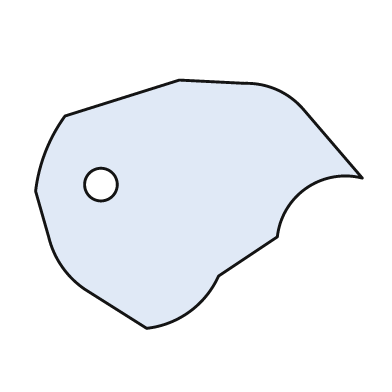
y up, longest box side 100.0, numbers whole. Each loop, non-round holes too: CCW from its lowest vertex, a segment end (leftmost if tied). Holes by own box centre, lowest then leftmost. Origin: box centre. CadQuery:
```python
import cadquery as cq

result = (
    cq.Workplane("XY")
    .moveTo(-16.0, -38.0)
    .threePointArc((-3.0, -33.0), (6.0, -22.0))
    .lineTo(24.0, -10.0)
    .threePointArc((33.0, 5.0), (50.0, 8.0))
    .lineTo(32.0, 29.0)
    .threePointArc((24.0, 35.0), (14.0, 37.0))
    .lineTo(-6.0, 38.0)
    .lineTo(-41.0, 27.0)
    .threePointArc((-47.0, 16.0), (-50.0, 4.0))
    .lineTo(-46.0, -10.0)
    .threePointArc((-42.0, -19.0), (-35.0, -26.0))
    .close()
    .moveTo(-30.0, 6.0)
    .circle(5.0)
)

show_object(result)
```